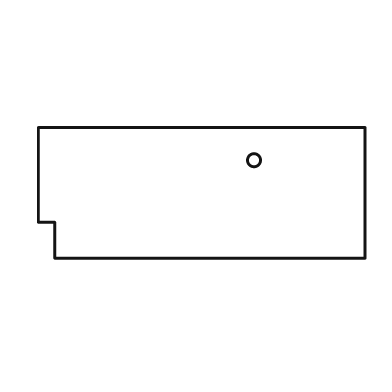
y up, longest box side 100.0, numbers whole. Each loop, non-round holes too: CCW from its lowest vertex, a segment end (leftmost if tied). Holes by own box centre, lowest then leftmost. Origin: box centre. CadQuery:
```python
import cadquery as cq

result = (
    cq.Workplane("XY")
    .moveTo(-45.0, -20.0)
    .lineTo(50.0, -20.0)
    .lineTo(50.0, 20.0)
    .lineTo(-50.0, 20.0)
    .lineTo(-50.0, -9.0)
    .lineTo(-45.0, -9.0)
    .close()
    .moveTo(16.0, 10.0)
    .circle(2.0)
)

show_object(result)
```